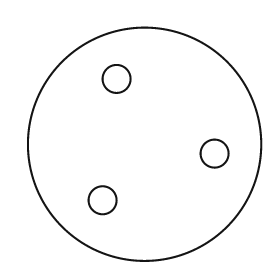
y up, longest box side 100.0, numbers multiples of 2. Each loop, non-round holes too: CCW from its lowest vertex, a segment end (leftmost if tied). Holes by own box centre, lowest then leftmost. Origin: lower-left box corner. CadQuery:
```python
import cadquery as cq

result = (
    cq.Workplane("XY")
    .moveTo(50.0, 50.0)
    .circle(50.0)
    .moveTo(32.0, 26.0)
    .circle(6.0)
    .moveTo(80.0, 46.0)
    .circle(6.0)
    .moveTo(38.0, 78.0)
    .circle(6.0)
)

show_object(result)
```